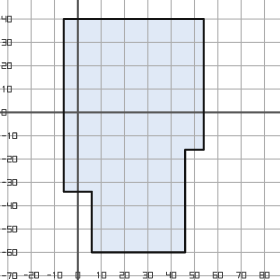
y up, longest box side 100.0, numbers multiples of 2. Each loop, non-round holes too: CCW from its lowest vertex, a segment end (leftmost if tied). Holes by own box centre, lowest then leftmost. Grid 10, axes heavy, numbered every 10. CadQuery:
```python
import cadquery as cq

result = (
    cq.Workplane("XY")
    .moveTo(6.0, -60.0)
    .lineTo(46.0, -60.0)
    .lineTo(46.0, -16.0)
    .lineTo(54.0, -16.0)
    .lineTo(54.0, 40.0)
    .lineTo(-6.0, 40.0)
    .lineTo(-6.0, -34.0)
    .lineTo(6.0, -34.0)
    .close()
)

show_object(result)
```